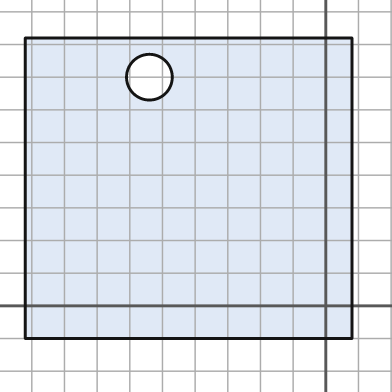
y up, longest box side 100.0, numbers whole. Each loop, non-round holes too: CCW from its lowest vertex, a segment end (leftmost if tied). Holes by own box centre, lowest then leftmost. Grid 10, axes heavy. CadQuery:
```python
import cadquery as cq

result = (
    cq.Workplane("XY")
    .moveTo(-92.0, -10.0)
    .lineTo(8.0, -10.0)
    .lineTo(8.0, 82.0)
    .lineTo(-92.0, 82.0)
    .close()
    .moveTo(-54.0, 70.0)
    .circle(7.0)
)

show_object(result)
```